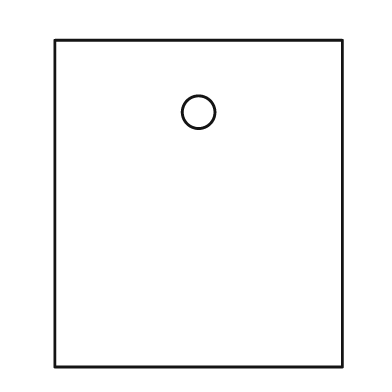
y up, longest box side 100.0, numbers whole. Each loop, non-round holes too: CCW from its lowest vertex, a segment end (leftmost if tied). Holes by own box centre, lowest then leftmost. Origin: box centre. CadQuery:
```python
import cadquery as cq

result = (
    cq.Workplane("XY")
    .moveTo(-44.0, -50.0)
    .lineTo(44.0, -50.0)
    .lineTo(44.0, 50.0)
    .lineTo(-44.0, 50.0)
    .close()
    .moveTo(0.0, 28.0)
    .circle(5.0)
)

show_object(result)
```